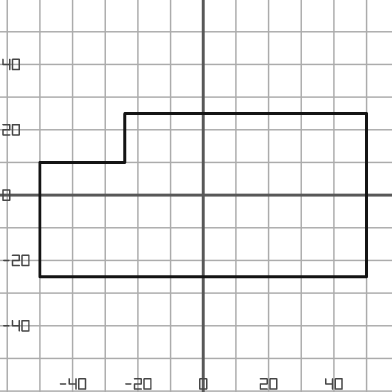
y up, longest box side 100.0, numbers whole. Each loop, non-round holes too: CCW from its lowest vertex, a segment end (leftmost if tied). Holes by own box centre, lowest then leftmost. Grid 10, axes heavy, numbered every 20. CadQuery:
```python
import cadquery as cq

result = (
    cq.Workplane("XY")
    .moveTo(-50.0, -25.0)
    .lineTo(50.0, -25.0)
    .lineTo(50.0, 25.0)
    .lineTo(-24.0, 25.0)
    .lineTo(-24.0, 10.0)
    .lineTo(-50.0, 10.0)
    .close()
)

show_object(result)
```